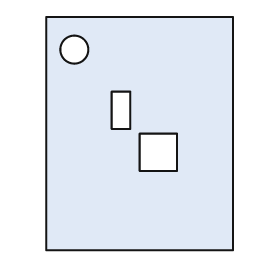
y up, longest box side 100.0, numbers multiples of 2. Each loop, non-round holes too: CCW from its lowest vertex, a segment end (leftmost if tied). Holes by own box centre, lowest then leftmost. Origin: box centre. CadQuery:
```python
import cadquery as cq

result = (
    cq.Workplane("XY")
    .moveTo(-40.0, -50.0)
    .lineTo(40.0, -50.0)
    .lineTo(40.0, 50.0)
    .lineTo(-40.0, 50.0)
    .close()
    .moveTo(0.0, -16.0)
    .lineTo(16.0, -16.0)
    .lineTo(16.0, 0.0)
    .lineTo(0.0, 0.0)
    .close()
    .moveTo(-12.0, 2.0)
    .lineTo(-4.0, 2.0)
    .lineTo(-4.0, 18.0)
    .lineTo(-12.0, 18.0)
    .close()
    .moveTo(-28.0, 36.0)
    .circle(6.0)
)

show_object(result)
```